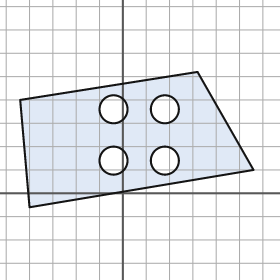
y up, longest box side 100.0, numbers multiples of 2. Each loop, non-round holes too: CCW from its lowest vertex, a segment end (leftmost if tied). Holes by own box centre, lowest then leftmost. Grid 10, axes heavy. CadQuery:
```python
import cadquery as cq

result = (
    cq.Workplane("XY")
    .moveTo(-40.0, -6.0)
    .lineTo(56.0, 10.0)
    .lineTo(32.0, 52.0)
    .lineTo(-44.0, 40.0)
    .close()
    .moveTo(-4.0, 14.0)
    .circle(6.0)
    .moveTo(18.0, 14.0)
    .circle(6.0)
    .moveTo(-4.0, 36.0)
    .circle(6.0)
    .moveTo(18.0, 36.0)
    .circle(6.0)
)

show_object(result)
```